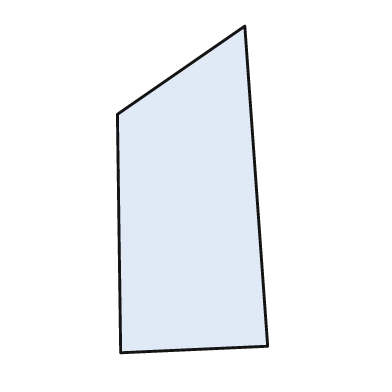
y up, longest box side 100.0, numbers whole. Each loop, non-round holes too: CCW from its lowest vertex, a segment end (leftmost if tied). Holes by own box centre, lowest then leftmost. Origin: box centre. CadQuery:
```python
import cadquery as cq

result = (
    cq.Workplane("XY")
    .moveTo(-22.0, -50.0)
    .lineTo(23.0, -48.0)
    .lineTo(16.0, 50.0)
    .lineTo(-23.0, 23.0)
    .close()
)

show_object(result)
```